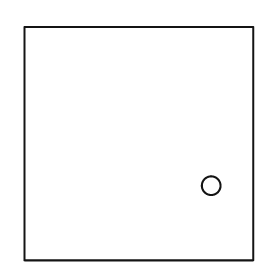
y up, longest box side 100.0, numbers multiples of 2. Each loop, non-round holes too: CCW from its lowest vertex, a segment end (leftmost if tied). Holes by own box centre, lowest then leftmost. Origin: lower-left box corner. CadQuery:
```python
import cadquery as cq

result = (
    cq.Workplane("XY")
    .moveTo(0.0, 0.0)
    .lineTo(98.0, 0.0)
    .lineTo(98.0, 100.0)
    .lineTo(0.0, 100.0)
    .close()
    .moveTo(80.0, 32.0)
    .circle(4.0)
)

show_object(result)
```